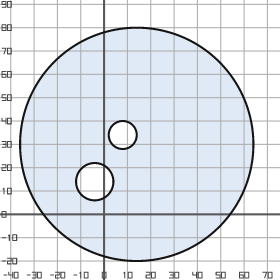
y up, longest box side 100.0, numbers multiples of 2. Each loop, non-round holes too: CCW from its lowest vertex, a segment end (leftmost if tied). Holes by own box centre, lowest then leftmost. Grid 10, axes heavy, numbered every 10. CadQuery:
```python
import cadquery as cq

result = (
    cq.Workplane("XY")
    .moveTo(14.0, 30.0)
    .circle(50.0)
    .moveTo(-4.0, 14.0)
    .circle(8.0)
    .moveTo(8.0, 34.0)
    .circle(6.0)
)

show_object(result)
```